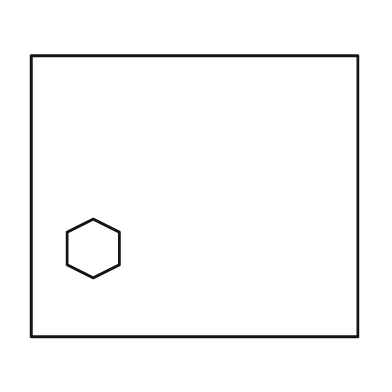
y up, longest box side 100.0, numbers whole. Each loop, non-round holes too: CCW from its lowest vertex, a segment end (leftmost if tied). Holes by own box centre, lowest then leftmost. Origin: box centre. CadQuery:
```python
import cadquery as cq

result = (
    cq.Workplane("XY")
    .moveTo(-50.0, -43.0)
    .lineTo(50.0, -43.0)
    .lineTo(50.0, 43.0)
    .lineTo(-50.0, 43.0)
    .close()
    .moveTo(-31.0, -25.0)
    .lineTo(-23.0, -21.0)
    .lineTo(-23.0, -11.0)
    .lineTo(-31.0, -7.0)
    .lineTo(-39.0, -11.0)
    .lineTo(-39.0, -21.0)
    .close()
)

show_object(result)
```